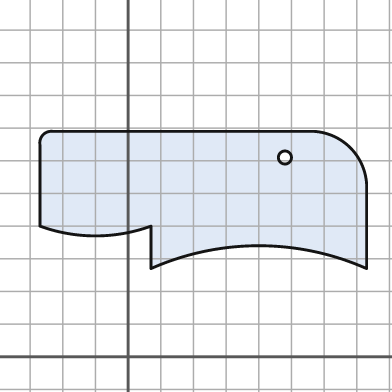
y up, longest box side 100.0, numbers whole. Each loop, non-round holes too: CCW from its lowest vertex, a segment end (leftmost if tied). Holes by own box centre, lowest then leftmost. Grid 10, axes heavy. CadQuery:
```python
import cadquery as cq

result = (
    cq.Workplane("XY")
    .moveTo(7.0, 27.0)
    .threePointArc((40.0, 34.0), (73.0, 27.0))
    .lineTo(73.0, 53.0)
    .threePointArc((68.0, 64.0), (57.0, 69.0))
    .lineTo(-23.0, 69.0)
    .threePointArc((-26.0, 68.0), (-27.0, 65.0))
    .lineTo(-27.0, 40.0)
    .threePointArc((-10.0, 37.0), (7.0, 40.0))
    .close()
    .moveTo(48.0, 61.0)
    .circle(2.0)
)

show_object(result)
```